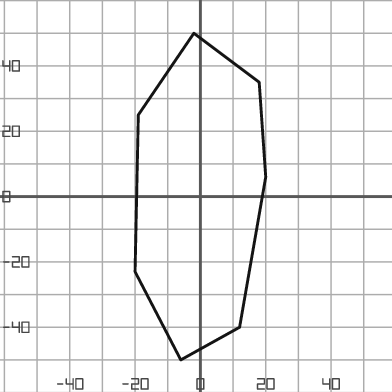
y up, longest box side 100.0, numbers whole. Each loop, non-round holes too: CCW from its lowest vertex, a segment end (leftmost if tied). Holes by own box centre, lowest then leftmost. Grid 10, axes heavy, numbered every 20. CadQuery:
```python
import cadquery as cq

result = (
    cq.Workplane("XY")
    .moveTo(-6.0, -50.0)
    .lineTo(12.0, -40.0)
    .lineTo(20.0, 6.0)
    .lineTo(18.0, 35.0)
    .lineTo(-2.0, 50.0)
    .lineTo(-19.0, 25.0)
    .lineTo(-20.0, -23.0)
    .close()
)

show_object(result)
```